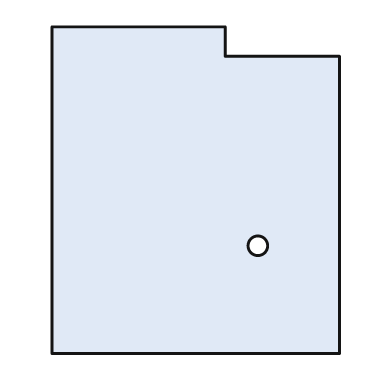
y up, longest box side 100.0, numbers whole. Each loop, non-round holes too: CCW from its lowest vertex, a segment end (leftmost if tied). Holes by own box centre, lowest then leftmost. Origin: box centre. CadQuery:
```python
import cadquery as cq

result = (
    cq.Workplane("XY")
    .moveTo(-44.0, -50.0)
    .lineTo(44.0, -50.0)
    .lineTo(44.0, 41.0)
    .lineTo(9.0, 41.0)
    .lineTo(9.0, 50.0)
    .lineTo(-44.0, 50.0)
    .close()
    .moveTo(19.0, -17.0)
    .circle(3.0)
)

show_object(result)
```